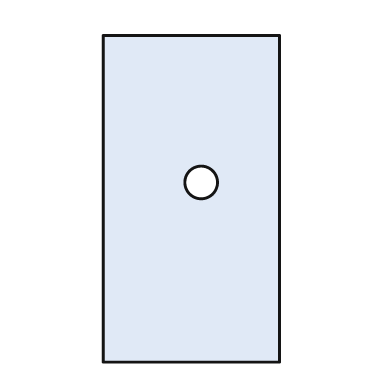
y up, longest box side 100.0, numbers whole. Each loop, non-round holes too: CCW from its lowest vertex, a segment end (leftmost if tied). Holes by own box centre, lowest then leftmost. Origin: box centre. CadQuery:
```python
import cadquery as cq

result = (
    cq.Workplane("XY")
    .moveTo(-27.0, -50.0)
    .lineTo(27.0, -50.0)
    .lineTo(27.0, 50.0)
    .lineTo(-27.0, 50.0)
    .close()
    .moveTo(3.0, 5.0)
    .circle(5.0)
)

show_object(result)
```